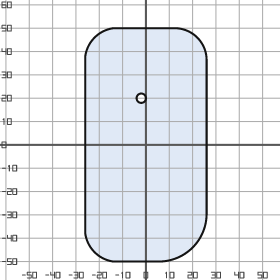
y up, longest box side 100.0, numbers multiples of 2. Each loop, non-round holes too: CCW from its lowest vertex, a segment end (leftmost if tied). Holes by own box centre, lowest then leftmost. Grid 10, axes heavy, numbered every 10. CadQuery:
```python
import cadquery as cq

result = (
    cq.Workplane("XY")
    .moveTo(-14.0, -50.0)
    .lineTo(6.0, -50.0)
    .threePointArc((20.0, -44.0), (26.0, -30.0))
    .lineTo(26.0, 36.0)
    .threePointArc((22.0, 46.0), (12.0, 50.0))
    .lineTo(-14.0, 50.0)
    .threePointArc((-22.0, 46.0), (-26.0, 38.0))
    .lineTo(-26.0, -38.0)
    .threePointArc((-22.0, -46.0), (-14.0, -50.0))
    .close()
    .moveTo(-2.0, 20.0)
    .circle(2.0)
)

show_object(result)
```